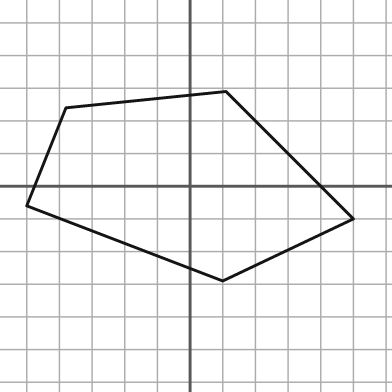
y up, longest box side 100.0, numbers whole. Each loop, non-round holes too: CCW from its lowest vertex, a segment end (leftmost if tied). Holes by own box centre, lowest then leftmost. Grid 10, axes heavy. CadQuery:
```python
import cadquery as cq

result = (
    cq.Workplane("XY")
    .moveTo(10.0, -29.0)
    .lineTo(50.0, -10.0)
    .lineTo(11.0, 29.0)
    .lineTo(-38.0, 24.0)
    .lineTo(-50.0, -6.0)
    .close()
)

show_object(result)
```